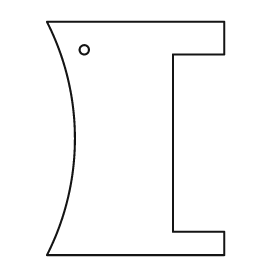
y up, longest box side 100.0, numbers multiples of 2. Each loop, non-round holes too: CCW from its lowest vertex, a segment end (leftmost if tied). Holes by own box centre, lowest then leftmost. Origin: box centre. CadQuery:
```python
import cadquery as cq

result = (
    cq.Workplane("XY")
    .moveTo(-38.0, -50.0)
    .lineTo(38.0, -50.0)
    .lineTo(38.0, -40.0)
    .lineTo(16.0, -40.0)
    .lineTo(16.0, 36.0)
    .lineTo(38.0, 36.0)
    .lineTo(38.0, 50.0)
    .lineTo(-38.0, 50.0)
    .threePointArc((-26.0, 0.0), (-38.0, -50.0))
    .close()
    .moveTo(-22.0, 38.0)
    .circle(2.0)
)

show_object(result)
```